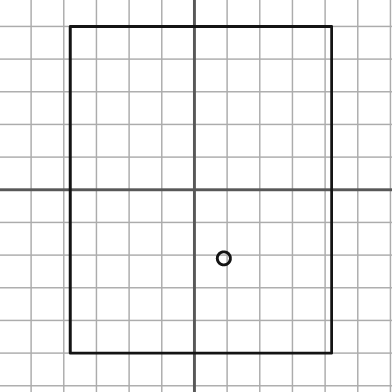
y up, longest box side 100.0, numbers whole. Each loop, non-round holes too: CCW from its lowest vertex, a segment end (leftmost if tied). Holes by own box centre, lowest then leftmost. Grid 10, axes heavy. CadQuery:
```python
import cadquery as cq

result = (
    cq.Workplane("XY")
    .moveTo(-38.0, -50.0)
    .lineTo(42.0, -50.0)
    .lineTo(42.0, 50.0)
    .lineTo(-38.0, 50.0)
    .close()
    .moveTo(9.0, -21.0)
    .circle(2.0)
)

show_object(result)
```